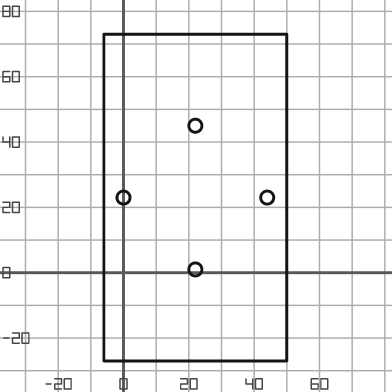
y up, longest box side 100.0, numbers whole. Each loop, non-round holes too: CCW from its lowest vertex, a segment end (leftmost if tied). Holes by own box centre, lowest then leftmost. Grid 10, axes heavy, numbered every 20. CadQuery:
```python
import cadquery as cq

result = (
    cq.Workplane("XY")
    .moveTo(-6.0, -27.0)
    .lineTo(50.0, -27.0)
    .lineTo(50.0, 73.0)
    .lineTo(-6.0, 73.0)
    .close()
    .moveTo(22.0, 1.0)
    .circle(2.0)
    .moveTo(0.0, 23.0)
    .circle(2.0)
    .moveTo(44.0, 23.0)
    .circle(2.0)
    .moveTo(22.0, 45.0)
    .circle(2.0)
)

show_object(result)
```